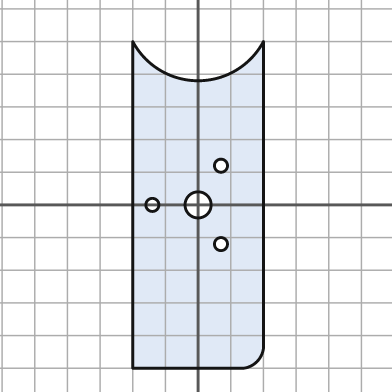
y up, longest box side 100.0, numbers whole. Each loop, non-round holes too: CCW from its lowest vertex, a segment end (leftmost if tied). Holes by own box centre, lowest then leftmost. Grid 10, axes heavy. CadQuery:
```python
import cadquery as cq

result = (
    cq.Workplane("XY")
    .moveTo(-20.0, -50.0)
    .lineTo(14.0, -50.0)
    .threePointArc((18.0, -48.0), (20.0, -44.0))
    .lineTo(20.0, 50.0)
    .threePointArc((0.0, 38.0), (-20.0, 50.0))
    .close()
    .moveTo(7.0, -12.0)
    .circle(2.0)
    .moveTo(-14.0, 0.0)
    .circle(2.0)
    .moveTo(0.0, 0.0)
    .circle(4.0)
    .moveTo(7.0, 12.0)
    .circle(2.0)
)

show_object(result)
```